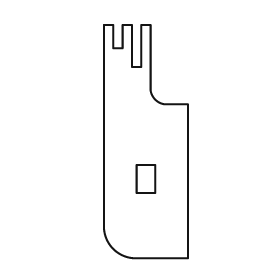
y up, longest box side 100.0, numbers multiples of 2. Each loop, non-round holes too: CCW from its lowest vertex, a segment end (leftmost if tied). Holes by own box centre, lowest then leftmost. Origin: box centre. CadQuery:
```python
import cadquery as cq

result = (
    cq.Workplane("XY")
    .moveTo(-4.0, -50.0)
    .lineTo(18.0, -50.0)
    .lineTo(18.0, 16.0)
    .lineTo(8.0, 16.0)
    .threePointArc((4.0, 18.0), (2.0, 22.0))
    .lineTo(2.0, 50.0)
    .lineTo(-2.0, 50.0)
    .lineTo(-2.0, 32.0)
    .lineTo(-6.0, 32.0)
    .lineTo(-6.0, 50.0)
    .lineTo(-10.0, 50.0)
    .lineTo(-10.0, 40.0)
    .lineTo(-14.0, 40.0)
    .lineTo(-14.0, 50.0)
    .lineTo(-18.0, 50.0)
    .lineTo(-18.0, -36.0)
    .threePointArc((-14.0, -46.0), (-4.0, -50.0))
    .close()
    .moveTo(-4.0, -22.0)
    .lineTo(4.0, -22.0)
    .lineTo(4.0, -10.0)
    .lineTo(-4.0, -10.0)
    .close()
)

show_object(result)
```